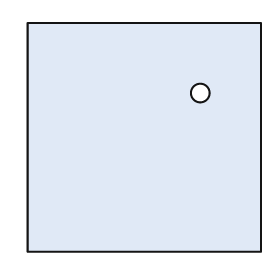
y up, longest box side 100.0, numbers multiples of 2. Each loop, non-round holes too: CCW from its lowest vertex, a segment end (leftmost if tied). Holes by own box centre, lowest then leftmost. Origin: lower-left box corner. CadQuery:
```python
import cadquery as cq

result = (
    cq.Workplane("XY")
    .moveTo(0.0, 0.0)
    .lineTo(100.0, 0.0)
    .lineTo(100.0, 98.0)
    .lineTo(0.0, 98.0)
    .close()
    .moveTo(74.0, 68.0)
    .circle(4.0)
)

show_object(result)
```